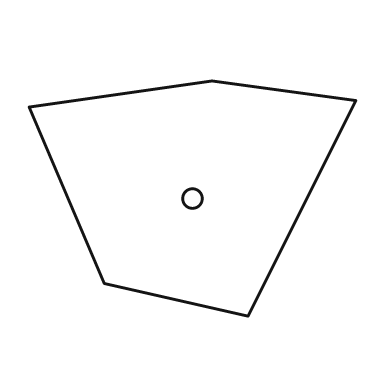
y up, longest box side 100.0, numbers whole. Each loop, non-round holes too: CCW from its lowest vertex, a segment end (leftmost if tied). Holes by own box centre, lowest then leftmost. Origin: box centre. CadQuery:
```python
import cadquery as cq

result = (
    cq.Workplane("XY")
    .moveTo(17.0, -36.0)
    .lineTo(50.0, 30.0)
    .lineTo(6.0, 36.0)
    .lineTo(-50.0, 28.0)
    .lineTo(-27.0, -26.0)
    .close()
    .moveTo(0.0, 0.0)
    .circle(3.0)
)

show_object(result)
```